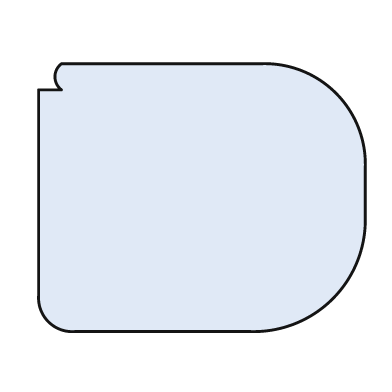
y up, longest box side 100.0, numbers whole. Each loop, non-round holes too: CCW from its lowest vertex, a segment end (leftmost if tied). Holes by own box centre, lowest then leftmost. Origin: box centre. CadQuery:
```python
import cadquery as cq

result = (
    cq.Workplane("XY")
    .moveTo(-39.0, -41.0)
    .lineTo(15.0, -41.0)
    .threePointArc((40.0, -31.0), (50.0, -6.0))
    .lineTo(50.0, 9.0)
    .threePointArc((41.0, 32.0), (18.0, 41.0))
    .lineTo(-43.0, 41.0)
    .threePointArc((-45.0, 37.0), (-43.0, 33.0))
    .lineTo(-50.0, 33.0)
    .lineTo(-50.0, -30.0)
    .threePointArc((-47.0, -38.0), (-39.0, -41.0))
    .close()
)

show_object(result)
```